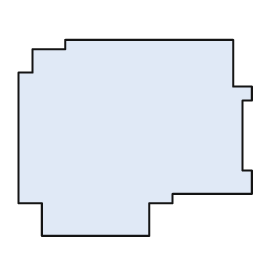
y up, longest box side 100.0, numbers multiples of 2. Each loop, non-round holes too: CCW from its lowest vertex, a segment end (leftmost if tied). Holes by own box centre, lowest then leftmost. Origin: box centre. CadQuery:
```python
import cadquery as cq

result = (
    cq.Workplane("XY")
    .moveTo(-40.0, -42.0)
    .lineTo(6.0, -42.0)
    .lineTo(6.0, -28.0)
    .lineTo(16.0, -28.0)
    .lineTo(16.0, -24.0)
    .lineTo(50.0, -24.0)
    .lineTo(50.0, -14.0)
    .lineTo(46.0, -14.0)
    .lineTo(46.0, 16.0)
    .lineTo(50.0, 16.0)
    .lineTo(50.0, 22.0)
    .lineTo(42.0, 22.0)
    .lineTo(42.0, 42.0)
    .lineTo(-30.0, 42.0)
    .lineTo(-30.0, 38.0)
    .lineTo(-44.0, 38.0)
    .lineTo(-44.0, 28.0)
    .lineTo(-50.0, 28.0)
    .lineTo(-50.0, -28.0)
    .lineTo(-40.0, -28.0)
    .close()
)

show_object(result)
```